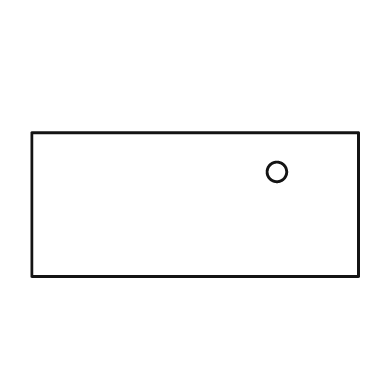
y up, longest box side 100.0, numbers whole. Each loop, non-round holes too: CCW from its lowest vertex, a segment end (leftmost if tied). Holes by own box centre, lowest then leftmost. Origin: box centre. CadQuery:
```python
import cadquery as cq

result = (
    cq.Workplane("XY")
    .moveTo(-50.0, -22.0)
    .lineTo(50.0, -22.0)
    .lineTo(50.0, 22.0)
    .lineTo(-50.0, 22.0)
    .close()
    .moveTo(25.0, 10.0)
    .circle(3.0)
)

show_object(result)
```